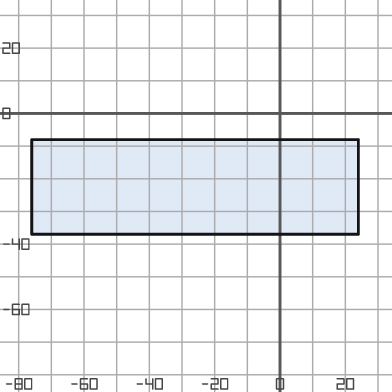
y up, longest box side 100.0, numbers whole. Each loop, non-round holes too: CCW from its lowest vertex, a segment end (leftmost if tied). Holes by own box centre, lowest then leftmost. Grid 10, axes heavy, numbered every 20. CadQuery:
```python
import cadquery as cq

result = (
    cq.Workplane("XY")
    .moveTo(-76.0, -37.0)
    .lineTo(24.0, -37.0)
    .lineTo(24.0, -8.0)
    .lineTo(-76.0, -8.0)
    .close()
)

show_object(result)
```